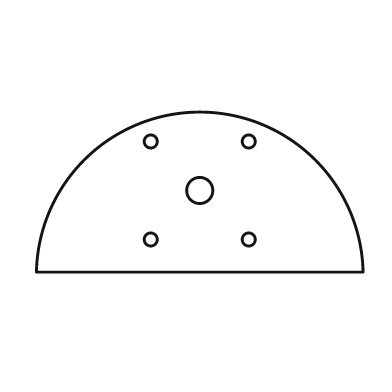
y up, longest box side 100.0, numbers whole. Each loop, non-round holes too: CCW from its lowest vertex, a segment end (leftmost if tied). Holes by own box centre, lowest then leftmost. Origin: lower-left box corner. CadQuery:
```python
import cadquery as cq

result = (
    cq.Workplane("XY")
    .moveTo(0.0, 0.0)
    .lineTo(100.0, 0.0)
    .threePointArc((50.0, 49.0), (0.0, 0.0))
    .close()
    .moveTo(35.0, 10.0)
    .circle(2.0)
    .moveTo(65.0, 10.0)
    .circle(2.0)
    .moveTo(50.0, 25.0)
    .circle(4.0)
    .moveTo(35.0, 40.0)
    .circle(2.0)
    .moveTo(65.0, 40.0)
    .circle(2.0)
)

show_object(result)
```